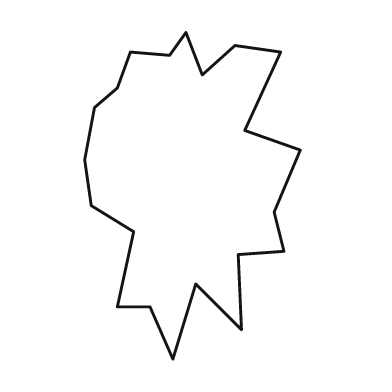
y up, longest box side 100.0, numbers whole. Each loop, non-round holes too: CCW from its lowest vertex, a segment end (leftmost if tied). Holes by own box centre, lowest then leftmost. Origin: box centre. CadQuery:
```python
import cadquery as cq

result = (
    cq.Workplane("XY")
    .moveTo(-6.0, -50.0)
    .lineTo(1.0, -27.0)
    .lineTo(15.0, -41.0)
    .lineTo(14.0, -18.0)
    .lineTo(28.0, -17.0)
    .lineTo(25.0, -5.0)
    .lineTo(33.0, 14.0)
    .lineTo(16.0, 20.0)
    .lineTo(27.0, 44.0)
    .lineTo(13.0, 46.0)
    .lineTo(3.0, 37.0)
    .lineTo(-2.0, 50.0)
    .lineTo(-7.0, 43.0)
    .lineTo(-19.0, 44.0)
    .lineTo(-23.0, 33.0)
    .lineTo(-30.0, 27.0)
    .lineTo(-33.0, 11.0)
    .lineTo(-31.0, -3.0)
    .lineTo(-18.0, -11.0)
    .lineTo(-23.0, -34.0)
    .lineTo(-13.0, -34.0)
    .close()
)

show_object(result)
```